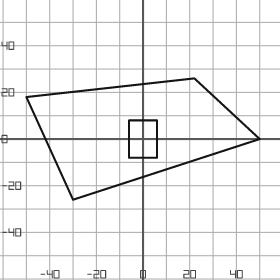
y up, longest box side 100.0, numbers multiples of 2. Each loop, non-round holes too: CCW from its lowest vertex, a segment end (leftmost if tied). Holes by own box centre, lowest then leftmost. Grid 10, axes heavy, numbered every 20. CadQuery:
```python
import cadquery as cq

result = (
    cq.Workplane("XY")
    .moveTo(-30.0, -26.0)
    .lineTo(50.0, 0.0)
    .lineTo(22.0, 26.0)
    .lineTo(-50.0, 18.0)
    .close()
    .moveTo(-6.0, -8.0)
    .lineTo(6.0, -8.0)
    .lineTo(6.0, 8.0)
    .lineTo(-6.0, 8.0)
    .close()
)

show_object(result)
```